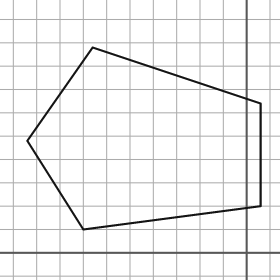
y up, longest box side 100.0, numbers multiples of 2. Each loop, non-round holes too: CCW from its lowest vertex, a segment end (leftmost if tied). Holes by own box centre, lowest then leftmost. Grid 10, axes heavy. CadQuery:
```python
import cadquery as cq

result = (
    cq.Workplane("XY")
    .moveTo(-70.0, 10.0)
    .lineTo(6.0, 20.0)
    .lineTo(6.0, 64.0)
    .lineTo(-66.0, 88.0)
    .lineTo(-94.0, 48.0)
    .close()
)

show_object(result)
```